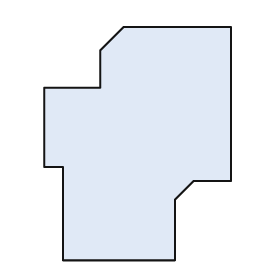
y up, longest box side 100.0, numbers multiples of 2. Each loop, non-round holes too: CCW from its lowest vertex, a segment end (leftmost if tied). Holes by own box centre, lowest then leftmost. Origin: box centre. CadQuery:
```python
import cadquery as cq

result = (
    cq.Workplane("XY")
    .moveTo(-32.0, -50.0)
    .lineTo(16.0, -50.0)
    .lineTo(16.0, -24.0)
    .lineTo(24.0, -16.0)
    .lineTo(40.0, -16.0)
    .lineTo(40.0, 50.0)
    .lineTo(-6.0, 50.0)
    .lineTo(-16.0, 40.0)
    .lineTo(-16.0, 24.0)
    .lineTo(-40.0, 24.0)
    .lineTo(-40.0, -10.0)
    .lineTo(-32.0, -10.0)
    .close()
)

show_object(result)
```